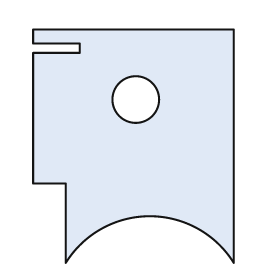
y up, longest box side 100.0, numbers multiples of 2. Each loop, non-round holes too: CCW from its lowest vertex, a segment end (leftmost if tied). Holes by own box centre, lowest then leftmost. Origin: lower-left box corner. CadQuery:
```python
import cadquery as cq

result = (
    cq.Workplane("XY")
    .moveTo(14.0, 0.0)
    .threePointArc((50.0, 20.0), (86.0, 0.0))
    .lineTo(86.0, 100.0)
    .lineTo(0.0, 100.0)
    .lineTo(0.0, 94.0)
    .lineTo(20.0, 94.0)
    .lineTo(20.0, 90.0)
    .lineTo(0.0, 90.0)
    .lineTo(0.0, 34.0)
    .lineTo(14.0, 34.0)
    .close()
    .moveTo(44.0, 70.0)
    .circle(10.0)
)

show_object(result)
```